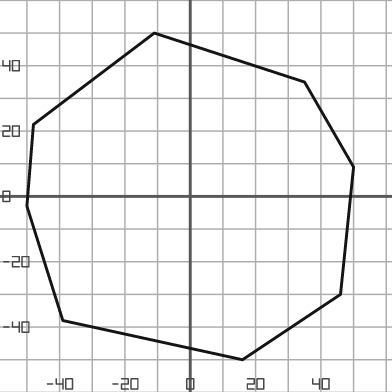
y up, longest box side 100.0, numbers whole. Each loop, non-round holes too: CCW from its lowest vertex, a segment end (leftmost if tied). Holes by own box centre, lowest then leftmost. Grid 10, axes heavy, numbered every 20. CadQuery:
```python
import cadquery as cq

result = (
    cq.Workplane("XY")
    .moveTo(16.0, -50.0)
    .lineTo(46.0, -30.0)
    .lineTo(50.0, 9.0)
    .lineTo(35.0, 35.0)
    .lineTo(-11.0, 50.0)
    .lineTo(-48.0, 22.0)
    .lineTo(-50.0, -3.0)
    .lineTo(-39.0, -38.0)
    .close()
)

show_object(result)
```